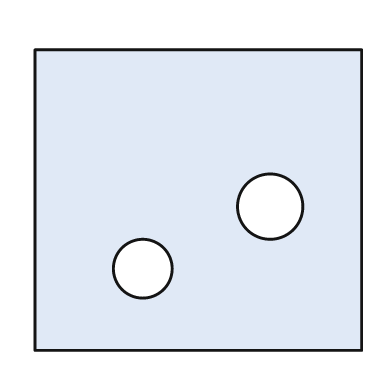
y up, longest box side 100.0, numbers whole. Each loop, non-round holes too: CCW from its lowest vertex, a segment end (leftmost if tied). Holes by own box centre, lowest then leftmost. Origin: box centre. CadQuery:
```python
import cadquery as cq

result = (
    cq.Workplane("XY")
    .moveTo(-50.0, -46.0)
    .lineTo(50.0, -46.0)
    .lineTo(50.0, 46.0)
    .lineTo(-50.0, 46.0)
    .close()
    .moveTo(-17.0, -21.0)
    .circle(9.0)
    .moveTo(22.0, -2.0)
    .circle(10.0)
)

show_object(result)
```